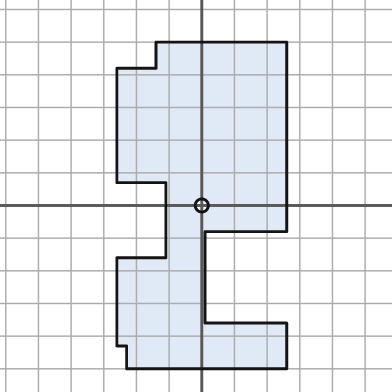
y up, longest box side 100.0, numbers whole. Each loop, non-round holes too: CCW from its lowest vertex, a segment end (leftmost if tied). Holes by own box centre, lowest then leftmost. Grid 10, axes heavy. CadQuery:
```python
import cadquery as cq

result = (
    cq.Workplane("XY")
    .moveTo(-23.0, -50.0)
    .lineTo(26.0, -50.0)
    .lineTo(26.0, -36.0)
    .lineTo(1.0, -36.0)
    .lineTo(1.0, -8.0)
    .lineTo(26.0, -8.0)
    .lineTo(26.0, 50.0)
    .lineTo(-14.0, 50.0)
    .lineTo(-14.0, 42.0)
    .lineTo(-26.0, 42.0)
    .lineTo(-26.0, 7.0)
    .lineTo(-11.0, 7.0)
    .lineTo(-11.0, -16.0)
    .lineTo(-26.0, -16.0)
    .lineTo(-26.0, -43.0)
    .lineTo(-23.0, -43.0)
    .close()
    .moveTo(0.0, 0.0)
    .circle(2.0)
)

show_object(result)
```